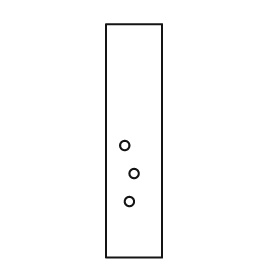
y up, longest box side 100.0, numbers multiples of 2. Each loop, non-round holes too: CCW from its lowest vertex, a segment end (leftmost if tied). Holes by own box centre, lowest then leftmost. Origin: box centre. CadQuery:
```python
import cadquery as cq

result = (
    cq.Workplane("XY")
    .moveTo(-12.0, -50.0)
    .lineTo(12.0, -50.0)
    .lineTo(12.0, 50.0)
    .lineTo(-12.0, 50.0)
    .close()
    .moveTo(-2.0, -26.0)
    .circle(2.0)
    .moveTo(0.0, -14.0)
    .circle(2.0)
    .moveTo(-4.0, -2.0)
    .circle(2.0)
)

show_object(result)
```